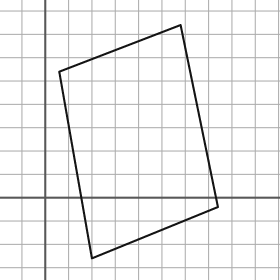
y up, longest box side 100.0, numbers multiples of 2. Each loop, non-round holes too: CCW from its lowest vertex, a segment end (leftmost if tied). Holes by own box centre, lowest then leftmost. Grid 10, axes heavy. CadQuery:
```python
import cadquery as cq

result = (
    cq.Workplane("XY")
    .moveTo(20.0, -26.0)
    .lineTo(74.0, -4.0)
    .lineTo(58.0, 74.0)
    .lineTo(6.0, 54.0)
    .close()
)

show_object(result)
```